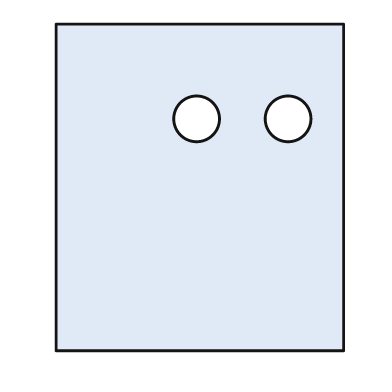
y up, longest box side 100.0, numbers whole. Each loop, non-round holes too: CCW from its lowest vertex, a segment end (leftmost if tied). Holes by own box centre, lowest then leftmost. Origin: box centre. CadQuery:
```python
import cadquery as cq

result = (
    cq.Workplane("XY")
    .moveTo(-44.0, -50.0)
    .lineTo(44.0, -50.0)
    .lineTo(44.0, 50.0)
    .lineTo(-44.0, 50.0)
    .close()
    .moveTo(-1.0, 21.0)
    .circle(7.0)
    .moveTo(27.0, 21.0)
    .circle(7.0)
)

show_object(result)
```